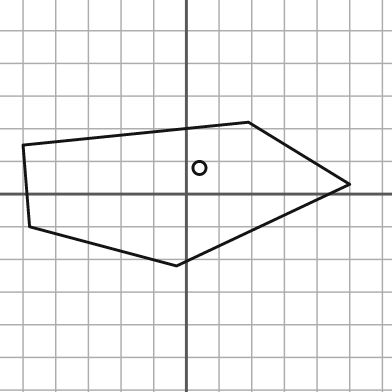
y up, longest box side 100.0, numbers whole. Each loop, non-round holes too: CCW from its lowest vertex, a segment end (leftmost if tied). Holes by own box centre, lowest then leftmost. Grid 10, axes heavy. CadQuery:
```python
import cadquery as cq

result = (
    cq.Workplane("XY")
    .moveTo(-3.0, -22.0)
    .lineTo(50.0, 3.0)
    .lineTo(19.0, 22.0)
    .lineTo(-50.0, 15.0)
    .lineTo(-48.0, -10.0)
    .close()
    .moveTo(4.0, 8.0)
    .circle(2.0)
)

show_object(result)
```